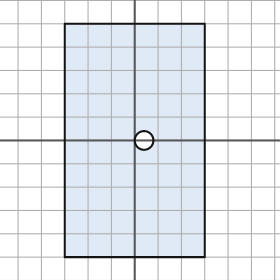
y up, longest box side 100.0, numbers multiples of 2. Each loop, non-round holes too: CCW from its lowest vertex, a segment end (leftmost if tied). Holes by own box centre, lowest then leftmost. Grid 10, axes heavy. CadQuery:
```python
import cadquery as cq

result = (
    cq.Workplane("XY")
    .moveTo(-30.0, -50.0)
    .lineTo(30.0, -50.0)
    .lineTo(30.0, 50.0)
    .lineTo(-30.0, 50.0)
    .close()
    .moveTo(4.0, 0.0)
    .circle(4.0)
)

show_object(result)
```